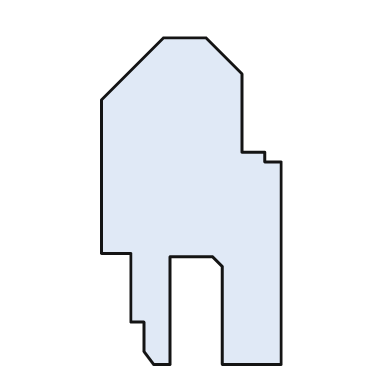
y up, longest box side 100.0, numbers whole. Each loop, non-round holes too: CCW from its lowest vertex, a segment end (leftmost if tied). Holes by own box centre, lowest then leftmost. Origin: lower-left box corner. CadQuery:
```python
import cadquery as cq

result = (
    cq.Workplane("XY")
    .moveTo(16.0, 0.0)
    .lineTo(21.0, 0.0)
    .lineTo(21.0, 33.0)
    .lineTo(34.0, 33.0)
    .lineTo(37.0, 30.0)
    .lineTo(37.0, 0.0)
    .lineTo(55.0, 0.0)
    .lineTo(55.0, 62.0)
    .lineTo(50.0, 62.0)
    .lineTo(50.0, 65.0)
    .lineTo(43.0, 65.0)
    .lineTo(43.0, 89.0)
    .lineTo(32.0, 100.0)
    .lineTo(19.0, 100.0)
    .lineTo(0.0, 81.0)
    .lineTo(0.0, 34.0)
    .lineTo(9.0, 34.0)
    .lineTo(9.0, 13.0)
    .lineTo(13.0, 13.0)
    .lineTo(13.0, 4.0)
    .close()
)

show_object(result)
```